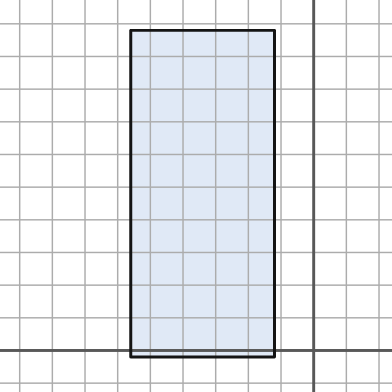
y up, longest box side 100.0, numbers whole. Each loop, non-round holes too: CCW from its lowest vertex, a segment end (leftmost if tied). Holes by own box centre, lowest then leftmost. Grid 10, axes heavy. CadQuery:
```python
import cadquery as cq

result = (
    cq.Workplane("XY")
    .moveTo(-56.0, -2.0)
    .lineTo(-12.0, -2.0)
    .lineTo(-12.0, 98.0)
    .lineTo(-56.0, 98.0)
    .close()
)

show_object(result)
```